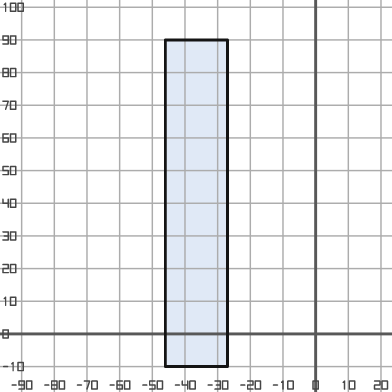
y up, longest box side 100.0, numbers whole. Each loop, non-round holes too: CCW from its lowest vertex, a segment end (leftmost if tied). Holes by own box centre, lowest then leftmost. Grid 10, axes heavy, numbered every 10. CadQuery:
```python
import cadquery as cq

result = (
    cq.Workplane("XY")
    .moveTo(-46.0, -10.0)
    .lineTo(-27.0, -10.0)
    .lineTo(-27.0, 90.0)
    .lineTo(-46.0, 90.0)
    .close()
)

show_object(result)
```